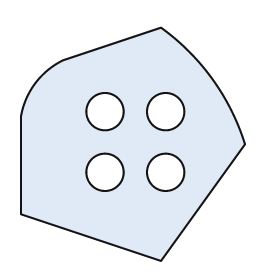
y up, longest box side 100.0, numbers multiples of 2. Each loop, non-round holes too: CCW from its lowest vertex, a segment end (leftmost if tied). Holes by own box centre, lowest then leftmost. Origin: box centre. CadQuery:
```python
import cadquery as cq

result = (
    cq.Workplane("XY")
    .moveTo(12.0, -50.0)
    .lineTo(48.0, 0.0)
    .threePointArc((34.0, 28.0), (12.0, 50.0))
    .lineTo(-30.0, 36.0)
    .threePointArc((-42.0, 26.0), (-48.0, 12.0))
    .lineTo(-48.0, -30.0)
    .close()
    .moveTo(-12.0, -12.0)
    .circle(8.0)
    .moveTo(14.0, -12.0)
    .circle(8.0)
    .moveTo(-12.0, 14.0)
    .circle(8.0)
    .moveTo(14.0, 14.0)
    .circle(8.0)
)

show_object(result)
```